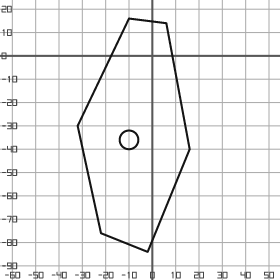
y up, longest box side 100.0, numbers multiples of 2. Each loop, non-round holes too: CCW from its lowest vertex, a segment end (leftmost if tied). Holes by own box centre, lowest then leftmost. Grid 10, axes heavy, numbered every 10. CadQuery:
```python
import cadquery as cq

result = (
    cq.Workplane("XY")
    .moveTo(-2.0, -84.0)
    .lineTo(16.0, -40.0)
    .lineTo(6.0, 14.0)
    .lineTo(-10.0, 16.0)
    .lineTo(-32.0, -30.0)
    .lineTo(-22.0, -76.0)
    .close()
    .moveTo(-10.0, -36.0)
    .circle(4.0)
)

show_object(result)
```